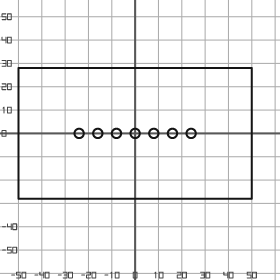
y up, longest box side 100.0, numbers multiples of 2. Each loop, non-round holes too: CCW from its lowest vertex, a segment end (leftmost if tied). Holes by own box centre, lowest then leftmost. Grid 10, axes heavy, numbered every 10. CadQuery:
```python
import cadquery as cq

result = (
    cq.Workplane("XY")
    .moveTo(-50.0, -28.0)
    .lineTo(50.0, -28.0)
    .lineTo(50.0, 28.0)
    .lineTo(-50.0, 28.0)
    .close()
    .moveTo(-24.0, 0.0)
    .circle(2.0)
    .moveTo(-16.0, 0.0)
    .circle(2.0)
    .moveTo(-8.0, 0.0)
    .circle(2.0)
    .moveTo(0.0, 0.0)
    .circle(2.0)
    .moveTo(8.0, 0.0)
    .circle(2.0)
    .moveTo(16.0, 0.0)
    .circle(2.0)
    .moveTo(24.0, 0.0)
    .circle(2.0)
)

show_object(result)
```